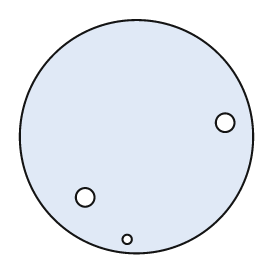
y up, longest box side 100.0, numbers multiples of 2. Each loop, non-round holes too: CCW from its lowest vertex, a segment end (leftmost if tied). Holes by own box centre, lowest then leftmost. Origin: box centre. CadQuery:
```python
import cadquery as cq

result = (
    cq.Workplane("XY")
    .moveTo(0.0, 0.0)
    .circle(50.0)
    .moveTo(-4.0, -44.0)
    .circle(2.0)
    .moveTo(-22.0, -26.0)
    .circle(4.0)
    .moveTo(38.0, 6.0)
    .circle(4.0)
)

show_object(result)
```